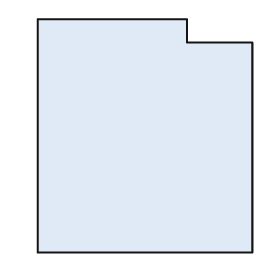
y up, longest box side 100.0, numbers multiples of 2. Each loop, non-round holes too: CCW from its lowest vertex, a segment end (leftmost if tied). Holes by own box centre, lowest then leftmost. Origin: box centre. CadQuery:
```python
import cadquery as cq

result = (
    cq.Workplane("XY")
    .moveTo(-46.0, -50.0)
    .lineTo(46.0, -50.0)
    .lineTo(46.0, 40.0)
    .lineTo(18.0, 40.0)
    .lineTo(18.0, 50.0)
    .lineTo(-46.0, 50.0)
    .close()
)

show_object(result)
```